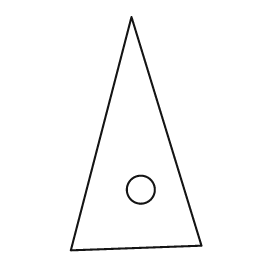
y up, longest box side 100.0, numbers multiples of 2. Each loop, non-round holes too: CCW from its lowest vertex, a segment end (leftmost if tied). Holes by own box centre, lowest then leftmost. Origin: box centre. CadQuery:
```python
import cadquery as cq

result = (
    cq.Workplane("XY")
    .moveTo(-28.0, -50.0)
    .lineTo(28.0, -48.0)
    .lineTo(-2.0, 50.0)
    .close()
    .moveTo(2.0, -24.0)
    .circle(6.0)
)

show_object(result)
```